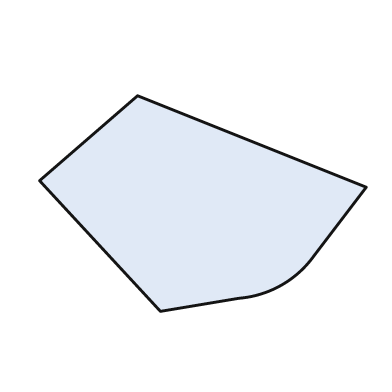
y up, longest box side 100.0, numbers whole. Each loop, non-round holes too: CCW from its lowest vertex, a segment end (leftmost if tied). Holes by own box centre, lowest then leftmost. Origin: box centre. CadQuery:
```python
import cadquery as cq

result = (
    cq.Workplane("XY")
    .moveTo(-13.0, -33.0)
    .lineTo(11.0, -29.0)
    .threePointArc((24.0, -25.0), (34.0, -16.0))
    .lineTo(50.0, 5.0)
    .lineTo(-20.0, 33.0)
    .lineTo(-50.0, 7.0)
    .close()
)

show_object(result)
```